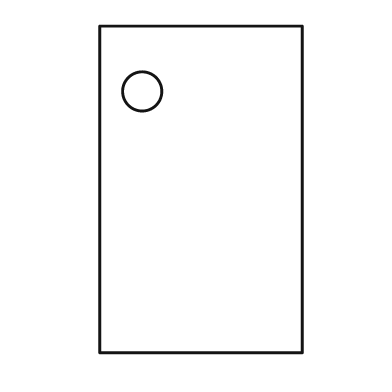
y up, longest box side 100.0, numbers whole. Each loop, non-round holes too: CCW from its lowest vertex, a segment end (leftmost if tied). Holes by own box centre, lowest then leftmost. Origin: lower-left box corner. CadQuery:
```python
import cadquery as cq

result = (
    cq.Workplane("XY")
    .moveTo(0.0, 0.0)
    .lineTo(62.0, 0.0)
    .lineTo(62.0, 100.0)
    .lineTo(0.0, 100.0)
    .close()
    .moveTo(13.0, 80.0)
    .circle(6.0)
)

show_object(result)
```